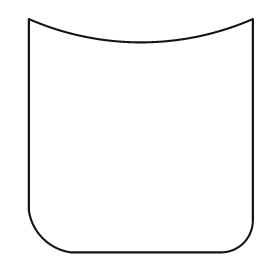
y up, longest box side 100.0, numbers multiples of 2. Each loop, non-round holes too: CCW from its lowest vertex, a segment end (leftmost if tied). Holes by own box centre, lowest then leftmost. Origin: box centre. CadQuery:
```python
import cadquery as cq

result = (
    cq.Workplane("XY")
    .moveTo(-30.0, -50.0)
    .lineTo(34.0, -50.0)
    .threePointArc((44.0, -46.0), (48.0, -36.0))
    .lineTo(48.0, 50.0)
    .threePointArc((0.0, 40.0), (-48.0, 50.0))
    .lineTo(-48.0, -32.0)
    .threePointArc((-42.0, -44.0), (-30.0, -50.0))
    .close()
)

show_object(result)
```